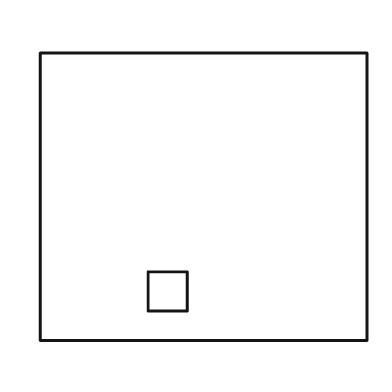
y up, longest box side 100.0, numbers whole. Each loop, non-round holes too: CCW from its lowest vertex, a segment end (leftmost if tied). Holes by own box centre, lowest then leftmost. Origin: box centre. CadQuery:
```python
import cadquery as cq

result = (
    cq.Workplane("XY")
    .moveTo(-50.0, -44.0)
    .lineTo(50.0, -44.0)
    .lineTo(50.0, 44.0)
    .lineTo(-50.0, 44.0)
    .close()
    .moveTo(-17.0, -35.0)
    .lineTo(-5.0, -35.0)
    .lineTo(-5.0, -23.0)
    .lineTo(-17.0, -23.0)
    .close()
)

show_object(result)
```